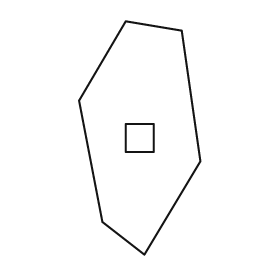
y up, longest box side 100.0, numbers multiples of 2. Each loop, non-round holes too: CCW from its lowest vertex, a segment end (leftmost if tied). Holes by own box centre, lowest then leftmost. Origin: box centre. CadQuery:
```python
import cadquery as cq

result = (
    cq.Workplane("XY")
    .moveTo(2.0, -50.0)
    .lineTo(26.0, -10.0)
    .lineTo(18.0, 46.0)
    .lineTo(-6.0, 50.0)
    .lineTo(-26.0, 16.0)
    .lineTo(-16.0, -36.0)
    .close()
    .moveTo(-6.0, -6.0)
    .lineTo(6.0, -6.0)
    .lineTo(6.0, 6.0)
    .lineTo(-6.0, 6.0)
    .close()
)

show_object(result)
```